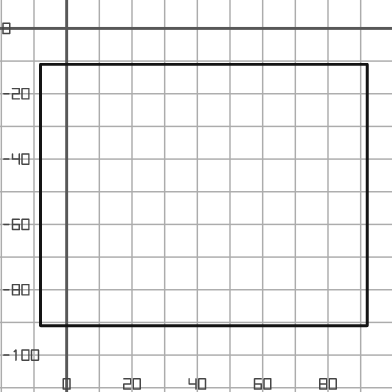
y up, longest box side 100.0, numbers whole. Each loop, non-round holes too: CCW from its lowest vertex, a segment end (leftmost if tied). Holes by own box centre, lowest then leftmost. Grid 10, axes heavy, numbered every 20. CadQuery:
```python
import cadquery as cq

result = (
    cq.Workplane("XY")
    .moveTo(-8.0, -91.0)
    .lineTo(92.0, -91.0)
    .lineTo(92.0, -11.0)
    .lineTo(-8.0, -11.0)
    .close()
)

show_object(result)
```